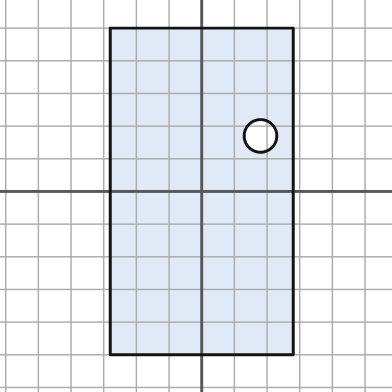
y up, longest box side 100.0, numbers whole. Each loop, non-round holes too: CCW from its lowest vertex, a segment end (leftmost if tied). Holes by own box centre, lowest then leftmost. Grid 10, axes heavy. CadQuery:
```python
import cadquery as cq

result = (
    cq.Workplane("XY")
    .moveTo(-28.0, -50.0)
    .lineTo(28.0, -50.0)
    .lineTo(28.0, 50.0)
    .lineTo(-28.0, 50.0)
    .close()
    .moveTo(18.0, 17.0)
    .circle(5.0)
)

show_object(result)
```